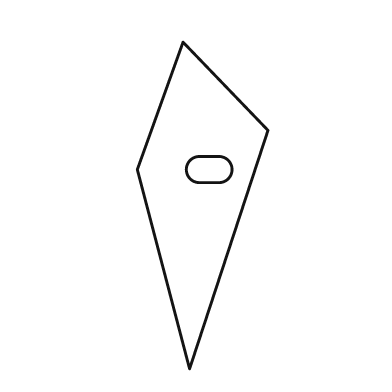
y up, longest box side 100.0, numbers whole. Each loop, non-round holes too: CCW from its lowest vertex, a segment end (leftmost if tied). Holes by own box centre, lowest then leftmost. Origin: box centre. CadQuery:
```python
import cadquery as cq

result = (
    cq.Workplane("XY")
    .moveTo(-4.0, -50.0)
    .lineTo(20.0, 23.0)
    .lineTo(-6.0, 50.0)
    .lineTo(-20.0, 11.0)
    .close()
    .moveTo(-1.0, 7.0)
    .lineTo(5.0, 7.0)
    .threePointArc((9.0, 11.0), (5.0, 15.0))
    .lineTo(-1.0, 15.0)
    .threePointArc((-5.0, 11.0), (-1.0, 7.0))
    .close()
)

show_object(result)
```